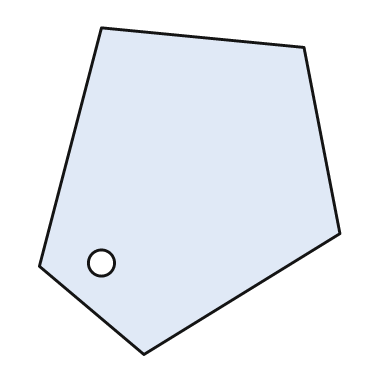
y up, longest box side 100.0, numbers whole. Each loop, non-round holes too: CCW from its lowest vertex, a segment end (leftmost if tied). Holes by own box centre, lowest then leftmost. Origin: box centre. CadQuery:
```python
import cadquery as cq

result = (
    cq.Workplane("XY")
    .moveTo(-14.0, -50.0)
    .lineTo(46.0, -13.0)
    .lineTo(35.0, 44.0)
    .lineTo(-27.0, 50.0)
    .lineTo(-46.0, -23.0)
    .close()
    .moveTo(-27.0, -22.0)
    .circle(4.0)
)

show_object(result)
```